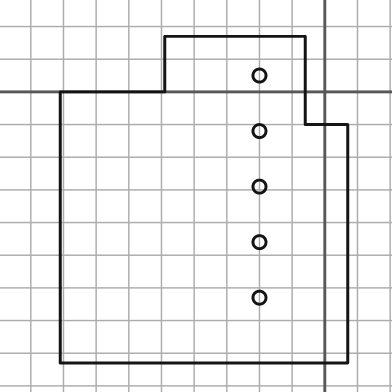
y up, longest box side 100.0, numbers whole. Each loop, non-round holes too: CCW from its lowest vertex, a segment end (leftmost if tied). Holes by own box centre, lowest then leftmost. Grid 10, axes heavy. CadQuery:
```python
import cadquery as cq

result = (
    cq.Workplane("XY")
    .moveTo(-81.0, -83.0)
    .lineTo(7.0, -83.0)
    .lineTo(7.0, -10.0)
    .lineTo(-6.0, -10.0)
    .lineTo(-6.0, 17.0)
    .lineTo(-49.0, 17.0)
    .lineTo(-49.0, 0.0)
    .lineTo(-81.0, 0.0)
    .close()
    .moveTo(-20.0, -63.0)
    .circle(2.0)
    .moveTo(-20.0, -46.0)
    .circle(2.0)
    .moveTo(-20.0, -29.0)
    .circle(2.0)
    .moveTo(-20.0, -12.0)
    .circle(2.0)
    .moveTo(-20.0, 5.0)
    .circle(2.0)
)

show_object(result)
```